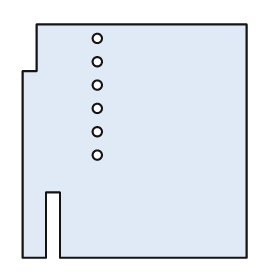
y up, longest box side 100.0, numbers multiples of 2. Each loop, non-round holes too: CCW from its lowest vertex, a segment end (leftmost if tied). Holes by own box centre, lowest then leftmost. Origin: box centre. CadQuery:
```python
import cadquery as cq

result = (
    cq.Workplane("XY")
    .moveTo(-48.0, -50.0)
    .lineTo(-38.0, -50.0)
    .lineTo(-38.0, -22.0)
    .lineTo(-32.0, -22.0)
    .lineTo(-32.0, -50.0)
    .lineTo(48.0, -50.0)
    .lineTo(48.0, 50.0)
    .lineTo(-42.0, 50.0)
    .lineTo(-42.0, 30.0)
    .lineTo(-48.0, 30.0)
    .close()
    .moveTo(-16.0, -6.0)
    .circle(2.0)
    .moveTo(-16.0, 4.0)
    .circle(2.0)
    .moveTo(-16.0, 14.0)
    .circle(2.0)
    .moveTo(-16.0, 24.0)
    .circle(2.0)
    .moveTo(-16.0, 34.0)
    .circle(2.0)
    .moveTo(-16.0, 44.0)
    .circle(2.0)
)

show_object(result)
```